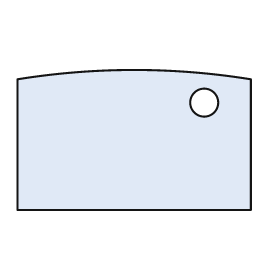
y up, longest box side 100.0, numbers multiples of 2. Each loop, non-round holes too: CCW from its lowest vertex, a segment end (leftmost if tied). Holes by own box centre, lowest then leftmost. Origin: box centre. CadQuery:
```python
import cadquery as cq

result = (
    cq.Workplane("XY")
    .moveTo(-50.0, -30.0)
    .lineTo(50.0, -30.0)
    .lineTo(50.0, 26.0)
    .threePointArc((0.0, 30.0), (-50.0, 26.0))
    .close()
    .moveTo(30.0, 16.0)
    .circle(6.0)
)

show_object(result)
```